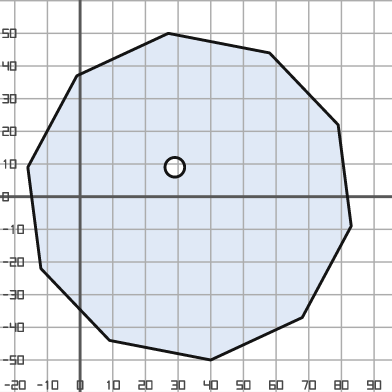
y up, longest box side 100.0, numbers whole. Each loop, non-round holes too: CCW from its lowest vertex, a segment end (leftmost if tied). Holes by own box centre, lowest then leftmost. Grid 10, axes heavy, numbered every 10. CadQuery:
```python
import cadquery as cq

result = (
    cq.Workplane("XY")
    .moveTo(40.0, -50.0)
    .lineTo(68.0, -37.0)
    .lineTo(83.0, -9.0)
    .lineTo(79.0, 22.0)
    .lineTo(58.0, 44.0)
    .lineTo(27.0, 50.0)
    .lineTo(-1.0, 37.0)
    .lineTo(-16.0, 9.0)
    .lineTo(-12.0, -22.0)
    .lineTo(9.0, -44.0)
    .close()
    .moveTo(29.0, 9.0)
    .circle(3.0)
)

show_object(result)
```